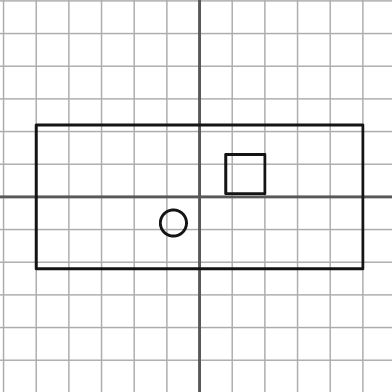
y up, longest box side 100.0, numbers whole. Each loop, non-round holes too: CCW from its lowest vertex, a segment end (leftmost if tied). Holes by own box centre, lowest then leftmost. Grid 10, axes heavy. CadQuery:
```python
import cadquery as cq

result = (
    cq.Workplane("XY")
    .moveTo(-50.0, -22.0)
    .lineTo(50.0, -22.0)
    .lineTo(50.0, 22.0)
    .lineTo(-50.0, 22.0)
    .close()
    .moveTo(-8.0, -8.0)
    .circle(4.0)
    .moveTo(8.0, 1.0)
    .lineTo(20.0, 1.0)
    .lineTo(20.0, 13.0)
    .lineTo(8.0, 13.0)
    .close()
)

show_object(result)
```